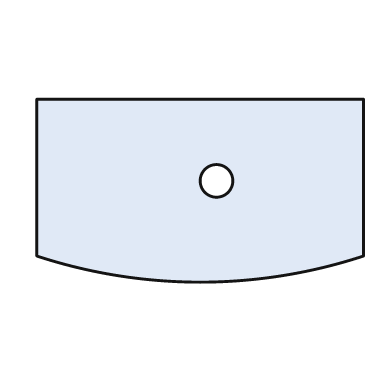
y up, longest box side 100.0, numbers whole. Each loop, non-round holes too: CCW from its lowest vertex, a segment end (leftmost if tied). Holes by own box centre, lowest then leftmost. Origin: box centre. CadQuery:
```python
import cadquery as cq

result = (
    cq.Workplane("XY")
    .moveTo(-50.0, -20.0)
    .threePointArc((0.0, -28.0), (50.0, -20.0))
    .lineTo(50.0, 28.0)
    .lineTo(-50.0, 28.0)
    .close()
    .moveTo(5.0, 3.0)
    .circle(5.0)
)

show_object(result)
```